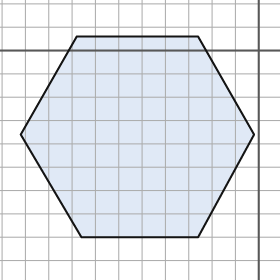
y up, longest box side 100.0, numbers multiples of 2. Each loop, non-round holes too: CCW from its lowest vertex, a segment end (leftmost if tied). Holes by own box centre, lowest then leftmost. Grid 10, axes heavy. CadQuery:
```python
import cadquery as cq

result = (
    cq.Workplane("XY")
    .moveTo(-76.0, -80.0)
    .lineTo(-26.0, -80.0)
    .lineTo(-2.0, -36.0)
    .lineTo(-26.0, 6.0)
    .lineTo(-78.0, 6.0)
    .lineTo(-102.0, -36.0)
    .close()
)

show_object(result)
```